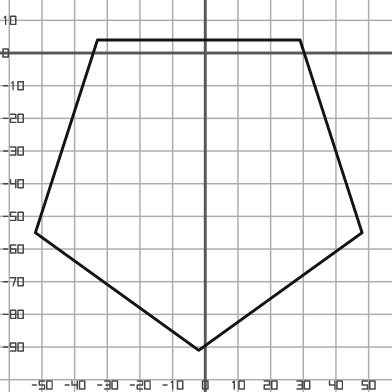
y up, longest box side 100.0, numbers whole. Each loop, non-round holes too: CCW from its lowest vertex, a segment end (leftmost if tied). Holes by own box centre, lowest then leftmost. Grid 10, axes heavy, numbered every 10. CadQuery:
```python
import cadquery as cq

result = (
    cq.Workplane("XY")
    .moveTo(-2.0, -91.0)
    .lineTo(48.0, -55.0)
    .lineTo(29.0, 4.0)
    .lineTo(-33.0, 4.0)
    .lineTo(-52.0, -55.0)
    .close()
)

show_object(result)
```